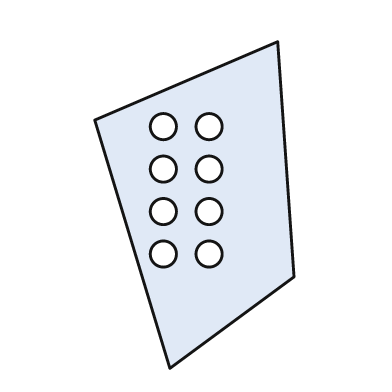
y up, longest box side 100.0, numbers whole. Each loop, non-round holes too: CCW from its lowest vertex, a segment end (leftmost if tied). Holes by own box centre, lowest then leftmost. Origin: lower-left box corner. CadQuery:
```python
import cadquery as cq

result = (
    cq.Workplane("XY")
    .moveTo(23.0, 0.0)
    .lineTo(61.0, 28.0)
    .lineTo(56.0, 100.0)
    .lineTo(0.0, 76.0)
    .close()
    .moveTo(21.0, 35.0)
    .circle(4.0)
    .moveTo(35.0, 35.0)
    .circle(4.0)
    .moveTo(21.0, 48.0)
    .circle(4.0)
    .moveTo(35.0, 48.0)
    .circle(4.0)
    .moveTo(21.0, 61.0)
    .circle(4.0)
    .moveTo(35.0, 61.0)
    .circle(4.0)
    .moveTo(21.0, 74.0)
    .circle(4.0)
    .moveTo(35.0, 74.0)
    .circle(4.0)
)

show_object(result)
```